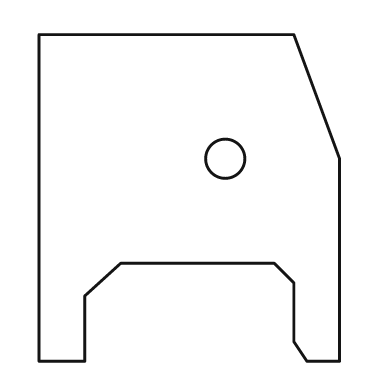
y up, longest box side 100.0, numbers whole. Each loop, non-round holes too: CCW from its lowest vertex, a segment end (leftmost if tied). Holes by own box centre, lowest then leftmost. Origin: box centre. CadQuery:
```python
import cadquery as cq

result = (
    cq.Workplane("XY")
    .moveTo(-46.0, -50.0)
    .lineTo(-32.0, -50.0)
    .lineTo(-32.0, -30.0)
    .lineTo(-21.0, -20.0)
    .lineTo(26.0, -20.0)
    .lineTo(32.0, -26.0)
    .lineTo(32.0, -44.0)
    .lineTo(36.0, -50.0)
    .lineTo(46.0, -50.0)
    .lineTo(46.0, 12.0)
    .lineTo(32.0, 50.0)
    .lineTo(-46.0, 50.0)
    .close()
    .moveTo(11.0, 12.0)
    .circle(6.0)
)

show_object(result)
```